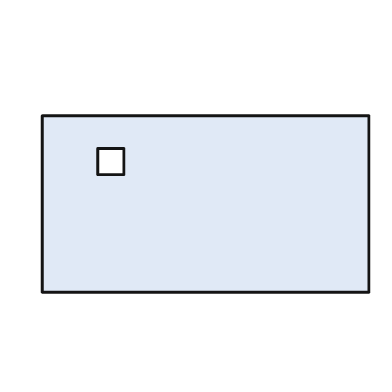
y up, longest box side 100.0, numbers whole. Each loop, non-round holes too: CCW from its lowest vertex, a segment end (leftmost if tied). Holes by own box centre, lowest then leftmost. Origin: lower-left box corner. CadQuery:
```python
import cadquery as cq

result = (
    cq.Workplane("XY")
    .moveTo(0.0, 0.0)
    .lineTo(100.0, 0.0)
    .lineTo(100.0, 54.0)
    .lineTo(0.0, 54.0)
    .close()
    .moveTo(17.0, 36.0)
    .lineTo(25.0, 36.0)
    .lineTo(25.0, 44.0)
    .lineTo(17.0, 44.0)
    .close()
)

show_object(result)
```